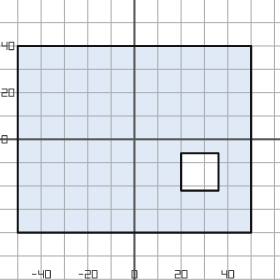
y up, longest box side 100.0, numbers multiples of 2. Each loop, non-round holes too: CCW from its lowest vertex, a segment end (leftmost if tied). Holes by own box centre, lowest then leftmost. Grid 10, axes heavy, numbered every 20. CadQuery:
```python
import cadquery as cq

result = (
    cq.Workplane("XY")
    .moveTo(-50.0, -40.0)
    .lineTo(50.0, -40.0)
    .lineTo(50.0, 40.0)
    .lineTo(-50.0, 40.0)
    .close()
    .moveTo(20.0, -22.0)
    .lineTo(36.0, -22.0)
    .lineTo(36.0, -6.0)
    .lineTo(20.0, -6.0)
    .close()
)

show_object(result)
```